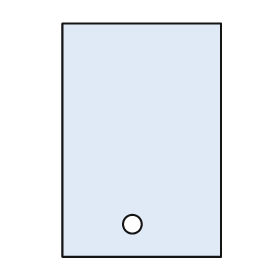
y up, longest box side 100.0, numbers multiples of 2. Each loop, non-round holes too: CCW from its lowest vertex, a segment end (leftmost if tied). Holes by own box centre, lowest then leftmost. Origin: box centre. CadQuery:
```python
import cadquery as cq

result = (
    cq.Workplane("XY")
    .moveTo(-34.0, -50.0)
    .lineTo(34.0, -50.0)
    .lineTo(34.0, 50.0)
    .lineTo(-34.0, 50.0)
    .close()
    .moveTo(-4.0, -36.0)
    .circle(4.0)
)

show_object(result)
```